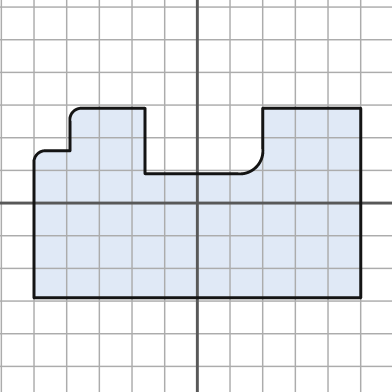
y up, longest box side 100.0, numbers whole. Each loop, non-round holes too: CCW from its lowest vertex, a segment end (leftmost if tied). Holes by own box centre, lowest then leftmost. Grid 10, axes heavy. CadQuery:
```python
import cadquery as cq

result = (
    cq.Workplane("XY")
    .moveTo(-50.0, -29.0)
    .lineTo(50.0, -29.0)
    .lineTo(50.0, 29.0)
    .lineTo(20.0, 29.0)
    .lineTo(20.0, 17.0)
    .threePointArc((18.0, 11.0), (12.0, 9.0))
    .lineTo(-16.0, 9.0)
    .lineTo(-16.0, 29.0)
    .lineTo(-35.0, 29.0)
    .threePointArc((-38.0, 28.0), (-39.0, 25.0))
    .lineTo(-39.0, 16.0)
    .lineTo(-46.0, 16.0)
    .threePointArc((-49.0, 15.0), (-50.0, 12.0))
    .close()
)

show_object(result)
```